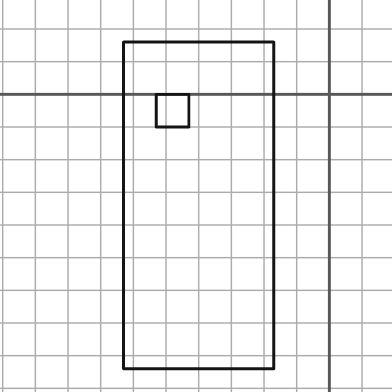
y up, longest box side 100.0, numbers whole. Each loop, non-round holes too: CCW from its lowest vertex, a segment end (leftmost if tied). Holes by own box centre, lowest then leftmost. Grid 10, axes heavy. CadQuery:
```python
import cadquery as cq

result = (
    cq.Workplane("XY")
    .moveTo(-63.0, -84.0)
    .lineTo(-17.0, -84.0)
    .lineTo(-17.0, 16.0)
    .lineTo(-63.0, 16.0)
    .close()
    .moveTo(-53.0, -10.0)
    .lineTo(-43.0, -10.0)
    .lineTo(-43.0, 0.0)
    .lineTo(-53.0, 0.0)
    .close()
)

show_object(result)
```